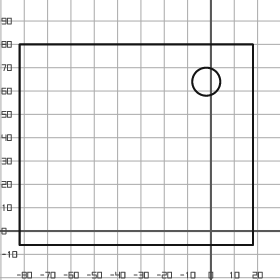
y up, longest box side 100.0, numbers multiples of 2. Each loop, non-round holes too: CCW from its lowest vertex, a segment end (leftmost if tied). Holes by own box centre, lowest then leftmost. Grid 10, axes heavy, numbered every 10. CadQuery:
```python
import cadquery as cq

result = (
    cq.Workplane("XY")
    .moveTo(-82.0, -6.0)
    .lineTo(18.0, -6.0)
    .lineTo(18.0, 80.0)
    .lineTo(-82.0, 80.0)
    .close()
    .moveTo(-2.0, 64.0)
    .circle(6.0)
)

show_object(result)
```